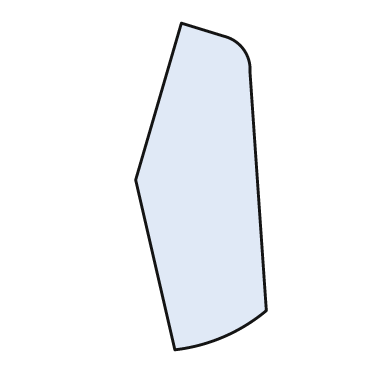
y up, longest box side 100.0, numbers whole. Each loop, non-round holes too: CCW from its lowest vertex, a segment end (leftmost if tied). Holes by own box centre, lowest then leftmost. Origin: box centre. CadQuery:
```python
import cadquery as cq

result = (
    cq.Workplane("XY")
    .moveTo(-8.0, -50.0)
    .threePointArc((7.0, -46.0), (20.0, -38.0))
    .lineTo(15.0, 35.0)
    .threePointArc((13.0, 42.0), (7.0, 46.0))
    .lineTo(-6.0, 50.0)
    .lineTo(-20.0, 2.0)
    .close()
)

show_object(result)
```